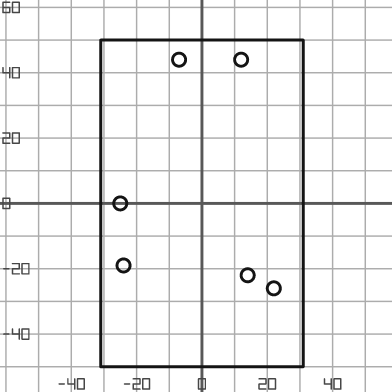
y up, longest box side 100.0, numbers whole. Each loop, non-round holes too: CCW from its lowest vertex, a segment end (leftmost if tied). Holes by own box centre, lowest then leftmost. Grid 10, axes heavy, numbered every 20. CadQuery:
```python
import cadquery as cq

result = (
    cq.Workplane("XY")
    .moveTo(-31.0, -50.0)
    .lineTo(31.0, -50.0)
    .lineTo(31.0, 50.0)
    .lineTo(-31.0, 50.0)
    .close()
    .moveTo(22.0, -26.0)
    .circle(2.0)
    .moveTo(14.0, -22.0)
    .circle(2.0)
    .moveTo(-24.0, -19.0)
    .circle(2.0)
    .moveTo(-25.0, 0.0)
    .circle(2.0)
    .moveTo(-7.0, 44.0)
    .circle(2.0)
    .moveTo(12.0, 44.0)
    .circle(2.0)
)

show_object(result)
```